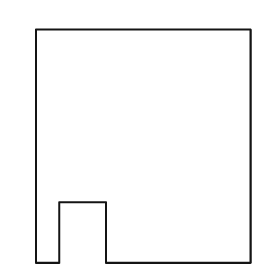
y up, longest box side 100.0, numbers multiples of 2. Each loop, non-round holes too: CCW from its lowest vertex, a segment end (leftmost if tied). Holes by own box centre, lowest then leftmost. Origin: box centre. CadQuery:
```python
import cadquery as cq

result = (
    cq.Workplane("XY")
    .moveTo(-46.0, -50.0)
    .lineTo(-36.0, -50.0)
    .lineTo(-36.0, -24.0)
    .lineTo(-16.0, -24.0)
    .lineTo(-16.0, -50.0)
    .lineTo(46.0, -50.0)
    .lineTo(46.0, 50.0)
    .lineTo(-46.0, 50.0)
    .close()
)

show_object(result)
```